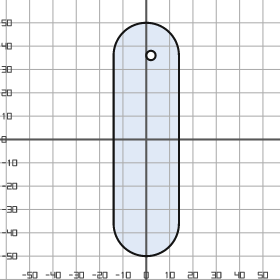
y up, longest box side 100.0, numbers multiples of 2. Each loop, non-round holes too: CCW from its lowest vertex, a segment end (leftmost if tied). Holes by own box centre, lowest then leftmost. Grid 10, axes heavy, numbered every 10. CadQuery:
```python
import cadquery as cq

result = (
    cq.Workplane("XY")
    .moveTo(-14.0, -36.0)
    .threePointArc((0.0, -50.0), (14.0, -36.0))
    .lineTo(14.0, 36.0)
    .threePointArc((0.0, 50.0), (-14.0, 36.0))
    .close()
    .moveTo(2.0, 36.0)
    .circle(2.0)
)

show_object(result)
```